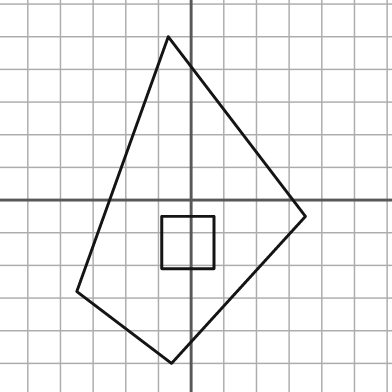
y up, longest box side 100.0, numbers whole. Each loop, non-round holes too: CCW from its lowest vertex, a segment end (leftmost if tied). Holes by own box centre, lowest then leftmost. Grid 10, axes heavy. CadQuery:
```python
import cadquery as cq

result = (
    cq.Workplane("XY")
    .moveTo(-6.0, -50.0)
    .lineTo(35.0, -5.0)
    .lineTo(-7.0, 50.0)
    .lineTo(-35.0, -28.0)
    .close()
    .moveTo(-9.0, -21.0)
    .lineTo(7.0, -21.0)
    .lineTo(7.0, -5.0)
    .lineTo(-9.0, -5.0)
    .close()
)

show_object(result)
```